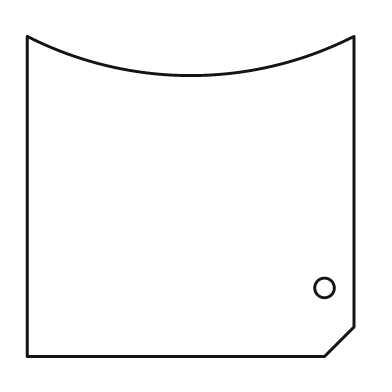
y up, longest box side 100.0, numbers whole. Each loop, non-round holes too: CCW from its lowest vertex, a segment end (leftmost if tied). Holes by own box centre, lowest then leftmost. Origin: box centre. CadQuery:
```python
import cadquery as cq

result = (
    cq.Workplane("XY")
    .moveTo(-50.0, -49.0)
    .lineTo(41.0, -49.0)
    .lineTo(50.0, -40.0)
    .lineTo(50.0, 49.0)
    .threePointArc((0.0, 37.0), (-50.0, 49.0))
    .close()
    .moveTo(41.0, -28.0)
    .circle(3.0)
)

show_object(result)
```